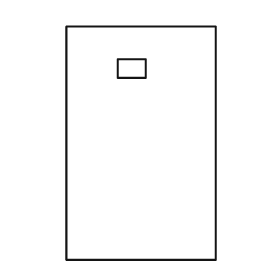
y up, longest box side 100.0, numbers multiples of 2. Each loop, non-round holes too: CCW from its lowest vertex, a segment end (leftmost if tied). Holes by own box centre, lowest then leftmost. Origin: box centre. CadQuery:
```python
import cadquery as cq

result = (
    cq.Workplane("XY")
    .moveTo(-32.0, -50.0)
    .lineTo(32.0, -50.0)
    .lineTo(32.0, 50.0)
    .lineTo(-32.0, 50.0)
    .close()
    .moveTo(-10.0, 28.0)
    .lineTo(2.0, 28.0)
    .lineTo(2.0, 36.0)
    .lineTo(-10.0, 36.0)
    .close()
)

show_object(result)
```